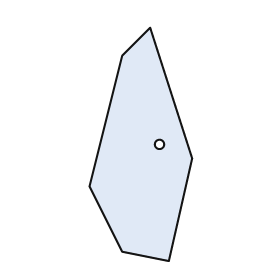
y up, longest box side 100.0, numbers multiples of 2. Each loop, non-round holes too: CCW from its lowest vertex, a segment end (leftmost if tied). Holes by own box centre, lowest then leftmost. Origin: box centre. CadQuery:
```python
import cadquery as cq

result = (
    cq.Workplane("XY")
    .moveTo(12.0, -50.0)
    .lineTo(22.0, -6.0)
    .lineTo(4.0, 50.0)
    .lineTo(-8.0, 38.0)
    .lineTo(-22.0, -18.0)
    .lineTo(-8.0, -46.0)
    .close()
    .moveTo(8.0, 0.0)
    .circle(2.0)
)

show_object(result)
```